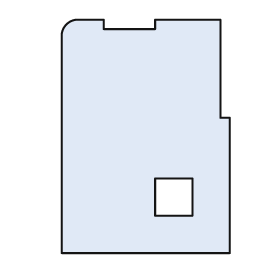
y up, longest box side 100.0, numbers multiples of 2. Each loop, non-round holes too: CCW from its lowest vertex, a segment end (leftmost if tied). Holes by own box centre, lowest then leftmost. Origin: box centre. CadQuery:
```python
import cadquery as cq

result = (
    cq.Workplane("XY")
    .moveTo(-36.0, -50.0)
    .lineTo(36.0, -50.0)
    .lineTo(36.0, 8.0)
    .lineTo(32.0, 8.0)
    .lineTo(32.0, 50.0)
    .lineTo(4.0, 50.0)
    .lineTo(4.0, 46.0)
    .lineTo(-18.0, 46.0)
    .lineTo(-18.0, 50.0)
    .lineTo(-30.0, 50.0)
    .threePointArc((-34.0, 48.0), (-36.0, 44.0))
    .close()
    .moveTo(4.0, -34.0)
    .lineTo(20.0, -34.0)
    .lineTo(20.0, -18.0)
    .lineTo(4.0, -18.0)
    .close()
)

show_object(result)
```